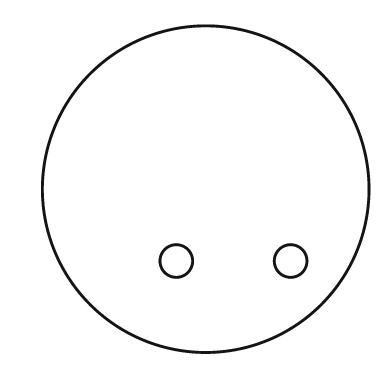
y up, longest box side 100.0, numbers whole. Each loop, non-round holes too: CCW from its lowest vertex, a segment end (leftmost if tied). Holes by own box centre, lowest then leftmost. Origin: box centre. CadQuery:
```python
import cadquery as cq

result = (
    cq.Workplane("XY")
    .moveTo(0.0, 0.0)
    .circle(50.0)
    .moveTo(-9.0, -22.0)
    .circle(5.0)
    .moveTo(26.0, -22.0)
    .circle(5.0)
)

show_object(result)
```